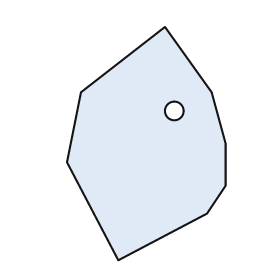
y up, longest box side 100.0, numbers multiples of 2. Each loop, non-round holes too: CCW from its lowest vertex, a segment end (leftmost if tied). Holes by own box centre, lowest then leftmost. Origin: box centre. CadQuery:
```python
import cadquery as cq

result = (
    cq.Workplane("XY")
    .moveTo(-12.0, -50.0)
    .lineTo(26.0, -30.0)
    .lineTo(34.0, -18.0)
    .lineTo(34.0, 0.0)
    .lineTo(28.0, 22.0)
    .lineTo(8.0, 50.0)
    .lineTo(-28.0, 22.0)
    .lineTo(-34.0, -8.0)
    .close()
    .moveTo(12.0, 14.0)
    .circle(4.0)
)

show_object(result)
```